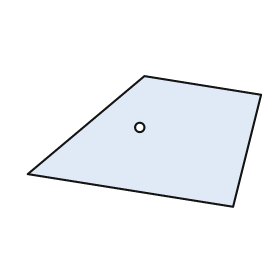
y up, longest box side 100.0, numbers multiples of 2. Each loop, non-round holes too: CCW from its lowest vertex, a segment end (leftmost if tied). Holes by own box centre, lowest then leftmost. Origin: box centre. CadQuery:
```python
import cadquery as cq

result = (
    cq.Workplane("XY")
    .moveTo(38.0, -28.0)
    .lineTo(50.0, 20.0)
    .lineTo(0.0, 28.0)
    .lineTo(-50.0, -14.0)
    .close()
    .moveTo(-2.0, 6.0)
    .circle(2.0)
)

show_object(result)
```